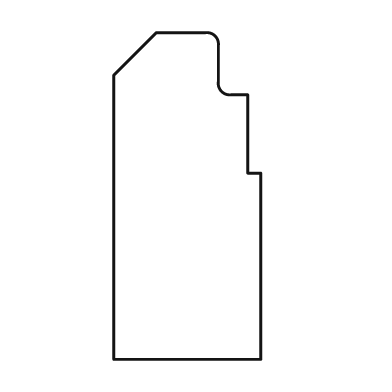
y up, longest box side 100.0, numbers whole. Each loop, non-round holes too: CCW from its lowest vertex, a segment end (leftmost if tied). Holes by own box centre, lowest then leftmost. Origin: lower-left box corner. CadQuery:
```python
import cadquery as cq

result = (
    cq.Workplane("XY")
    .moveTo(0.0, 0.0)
    .lineTo(45.0, 0.0)
    .lineTo(45.0, 57.0)
    .lineTo(41.0, 57.0)
    .lineTo(41.0, 81.0)
    .lineTo(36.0, 81.0)
    .threePointArc((33.0, 82.0), (32.0, 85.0))
    .lineTo(32.0, 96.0)
    .threePointArc((31.0, 99.0), (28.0, 100.0))
    .lineTo(13.0, 100.0)
    .lineTo(0.0, 87.0)
    .close()
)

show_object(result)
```